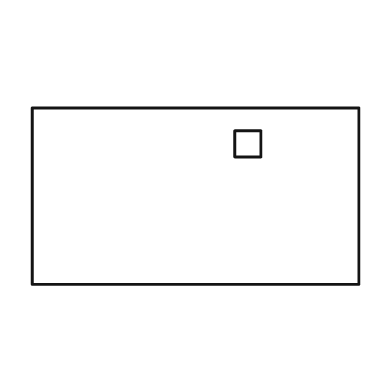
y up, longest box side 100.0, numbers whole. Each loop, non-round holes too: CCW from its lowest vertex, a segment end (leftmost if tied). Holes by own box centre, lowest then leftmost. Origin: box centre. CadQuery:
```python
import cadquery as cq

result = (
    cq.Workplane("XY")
    .moveTo(-50.0, -27.0)
    .lineTo(50.0, -27.0)
    .lineTo(50.0, 27.0)
    .lineTo(-50.0, 27.0)
    .close()
    .moveTo(12.0, 12.0)
    .lineTo(20.0, 12.0)
    .lineTo(20.0, 20.0)
    .lineTo(12.0, 20.0)
    .close()
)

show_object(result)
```